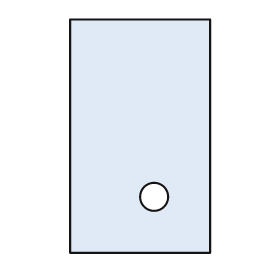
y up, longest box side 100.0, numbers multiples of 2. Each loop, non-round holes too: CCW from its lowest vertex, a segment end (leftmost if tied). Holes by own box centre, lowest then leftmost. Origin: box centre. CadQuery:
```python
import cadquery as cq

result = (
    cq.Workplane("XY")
    .moveTo(-30.0, -50.0)
    .lineTo(30.0, -50.0)
    .lineTo(30.0, 50.0)
    .lineTo(-30.0, 50.0)
    .close()
    .moveTo(6.0, -26.0)
    .circle(6.0)
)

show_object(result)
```